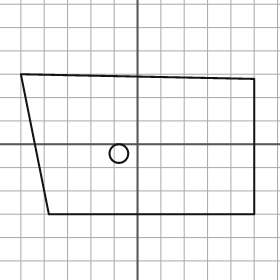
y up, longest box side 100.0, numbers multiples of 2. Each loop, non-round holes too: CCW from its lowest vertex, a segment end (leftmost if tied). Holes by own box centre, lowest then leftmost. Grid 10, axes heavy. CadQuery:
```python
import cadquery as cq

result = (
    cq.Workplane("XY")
    .moveTo(-38.0, -30.0)
    .lineTo(50.0, -30.0)
    .lineTo(50.0, 28.0)
    .lineTo(-50.0, 30.0)
    .close()
    .moveTo(-8.0, -4.0)
    .circle(4.0)
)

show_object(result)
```